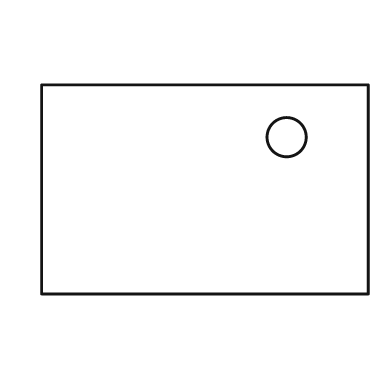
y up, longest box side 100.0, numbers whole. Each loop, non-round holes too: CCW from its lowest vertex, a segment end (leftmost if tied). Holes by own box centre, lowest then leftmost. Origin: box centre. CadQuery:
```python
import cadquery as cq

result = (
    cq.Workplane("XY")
    .moveTo(-50.0, -32.0)
    .lineTo(50.0, -32.0)
    .lineTo(50.0, 32.0)
    .lineTo(-50.0, 32.0)
    .close()
    .moveTo(25.0, 16.0)
    .circle(6.0)
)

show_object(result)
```